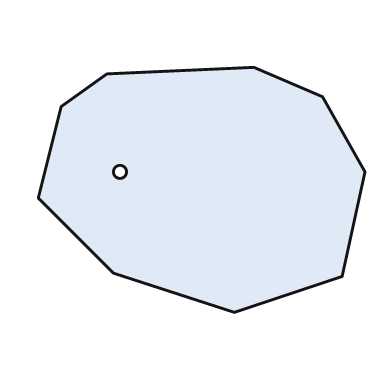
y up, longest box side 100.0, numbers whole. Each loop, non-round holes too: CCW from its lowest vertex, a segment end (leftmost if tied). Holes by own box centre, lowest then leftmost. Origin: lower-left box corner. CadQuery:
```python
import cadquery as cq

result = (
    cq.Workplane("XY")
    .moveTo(60.0, 0.0)
    .lineTo(93.0, 11.0)
    .lineTo(100.0, 43.0)
    .lineTo(87.0, 66.0)
    .lineTo(66.0, 75.0)
    .lineTo(21.0, 73.0)
    .lineTo(7.0, 63.0)
    .lineTo(0.0, 35.0)
    .lineTo(23.0, 12.0)
    .close()
    .moveTo(25.0, 43.0)
    .circle(2.0)
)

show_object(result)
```